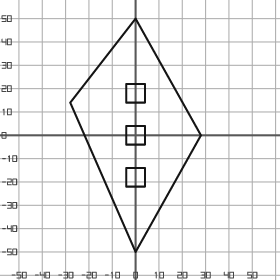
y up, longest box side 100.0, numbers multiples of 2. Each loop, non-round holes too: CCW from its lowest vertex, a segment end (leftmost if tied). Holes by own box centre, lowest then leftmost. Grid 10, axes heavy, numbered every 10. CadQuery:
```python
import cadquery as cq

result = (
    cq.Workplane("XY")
    .moveTo(0.0, -50.0)
    .lineTo(28.0, 0.0)
    .lineTo(0.0, 50.0)
    .lineTo(-28.0, 14.0)
    .close()
    .moveTo(-4.0, -22.0)
    .lineTo(4.0, -22.0)
    .lineTo(4.0, -14.0)
    .lineTo(-4.0, -14.0)
    .close()
    .moveTo(-4.0, -4.0)
    .lineTo(4.0, -4.0)
    .lineTo(4.0, 4.0)
    .lineTo(-4.0, 4.0)
    .close()
    .moveTo(-4.0, 14.0)
    .lineTo(4.0, 14.0)
    .lineTo(4.0, 22.0)
    .lineTo(-4.0, 22.0)
    .close()
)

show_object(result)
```